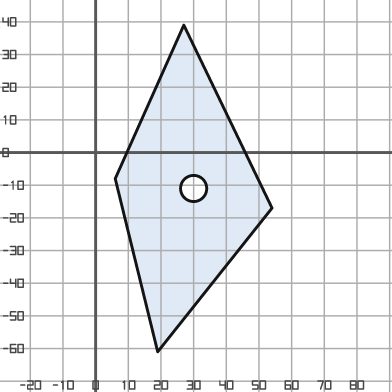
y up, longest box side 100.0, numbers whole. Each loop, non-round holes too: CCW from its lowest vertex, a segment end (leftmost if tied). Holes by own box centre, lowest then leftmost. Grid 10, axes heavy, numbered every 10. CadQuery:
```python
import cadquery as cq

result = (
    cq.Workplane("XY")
    .moveTo(19.0, -61.0)
    .lineTo(54.0, -17.0)
    .lineTo(27.0, 39.0)
    .lineTo(6.0, -8.0)
    .close()
    .moveTo(30.0, -11.0)
    .circle(4.0)
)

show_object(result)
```